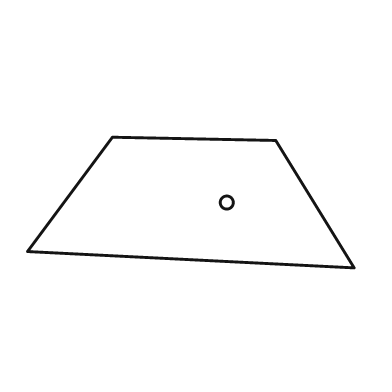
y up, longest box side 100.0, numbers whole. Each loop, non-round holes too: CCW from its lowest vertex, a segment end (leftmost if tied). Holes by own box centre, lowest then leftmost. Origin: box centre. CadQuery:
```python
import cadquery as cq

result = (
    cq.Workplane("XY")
    .moveTo(50.0, -20.0)
    .lineTo(26.0, 19.0)
    .lineTo(-24.0, 20.0)
    .lineTo(-50.0, -15.0)
    .close()
    .moveTo(11.0, 0.0)
    .circle(2.0)
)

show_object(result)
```